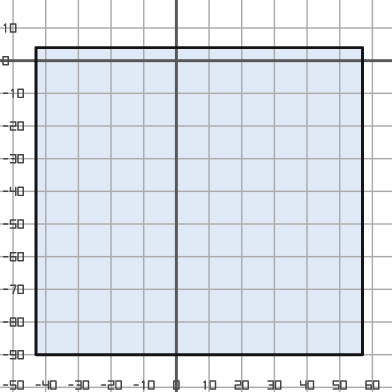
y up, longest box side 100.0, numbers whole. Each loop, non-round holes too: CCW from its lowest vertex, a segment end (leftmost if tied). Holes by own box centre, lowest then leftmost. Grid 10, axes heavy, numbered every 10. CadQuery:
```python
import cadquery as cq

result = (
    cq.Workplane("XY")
    .moveTo(-43.0, -90.0)
    .lineTo(57.0, -90.0)
    .lineTo(57.0, 4.0)
    .lineTo(-43.0, 4.0)
    .close()
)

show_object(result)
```